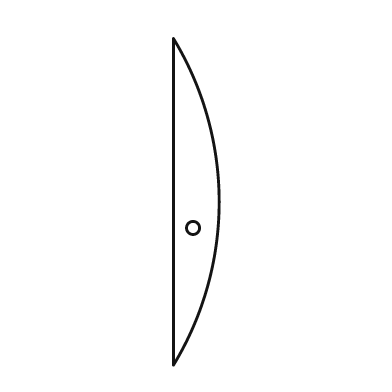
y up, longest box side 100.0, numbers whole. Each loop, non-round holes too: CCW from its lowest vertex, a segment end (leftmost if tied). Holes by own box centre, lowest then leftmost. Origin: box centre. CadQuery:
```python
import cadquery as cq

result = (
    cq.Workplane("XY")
    .moveTo(-7.0, -50.0)
    .threePointArc((7.0, 0.0), (-7.0, 50.0))
    .close()
    .moveTo(-1.0, -8.0)
    .circle(2.0)
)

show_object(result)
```